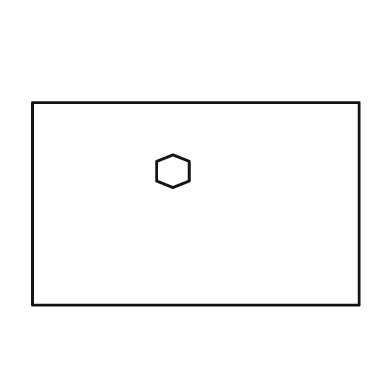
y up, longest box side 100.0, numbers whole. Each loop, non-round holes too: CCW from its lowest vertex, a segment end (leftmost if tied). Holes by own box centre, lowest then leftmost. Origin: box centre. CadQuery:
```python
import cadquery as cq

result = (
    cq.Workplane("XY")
    .moveTo(-50.0, -31.0)
    .lineTo(50.0, -31.0)
    .lineTo(50.0, 31.0)
    .lineTo(-50.0, 31.0)
    .close()
    .moveTo(-7.0, 5.0)
    .lineTo(-2.0, 7.0)
    .lineTo(-2.0, 13.0)
    .lineTo(-7.0, 15.0)
    .lineTo(-12.0, 13.0)
    .lineTo(-12.0, 7.0)
    .close()
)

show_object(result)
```